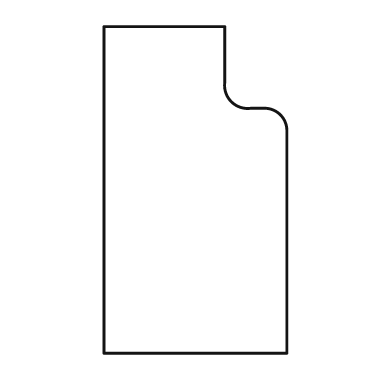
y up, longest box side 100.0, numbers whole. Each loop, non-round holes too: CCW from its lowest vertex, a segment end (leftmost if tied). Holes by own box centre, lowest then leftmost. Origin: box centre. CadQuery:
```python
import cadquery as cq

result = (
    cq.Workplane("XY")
    .moveTo(-28.0, -50.0)
    .lineTo(28.0, -50.0)
    .lineTo(28.0, 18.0)
    .threePointArc((26.0, 23.0), (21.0, 25.0))
    .lineTo(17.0, 25.0)
    .threePointArc((11.0, 27.0), (9.0, 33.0))
    .lineTo(9.0, 50.0)
    .lineTo(-28.0, 50.0)
    .close()
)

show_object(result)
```